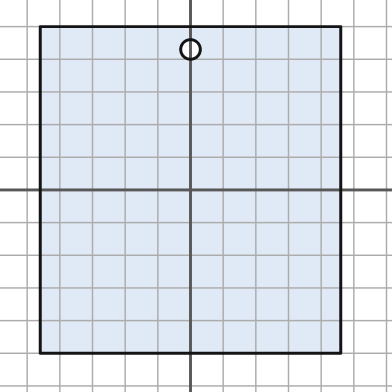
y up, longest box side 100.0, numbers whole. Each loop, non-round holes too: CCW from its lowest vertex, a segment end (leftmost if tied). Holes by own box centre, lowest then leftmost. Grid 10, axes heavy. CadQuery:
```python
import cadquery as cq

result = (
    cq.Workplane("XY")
    .moveTo(-46.0, -50.0)
    .lineTo(46.0, -50.0)
    .lineTo(46.0, 50.0)
    .lineTo(-46.0, 50.0)
    .close()
    .moveTo(0.0, 43.0)
    .circle(3.0)
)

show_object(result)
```